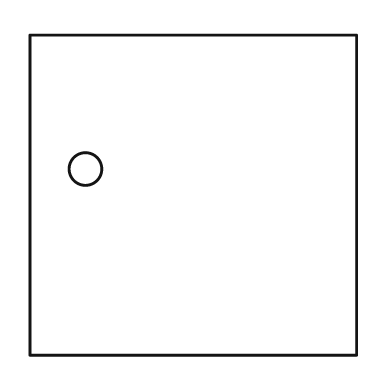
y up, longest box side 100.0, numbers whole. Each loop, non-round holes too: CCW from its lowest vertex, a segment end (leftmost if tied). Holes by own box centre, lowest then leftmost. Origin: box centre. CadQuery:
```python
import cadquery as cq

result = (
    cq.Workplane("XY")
    .moveTo(-50.0, -49.0)
    .lineTo(50.0, -49.0)
    .lineTo(50.0, 49.0)
    .lineTo(-50.0, 49.0)
    .close()
    .moveTo(-33.0, 8.0)
    .circle(5.0)
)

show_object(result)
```